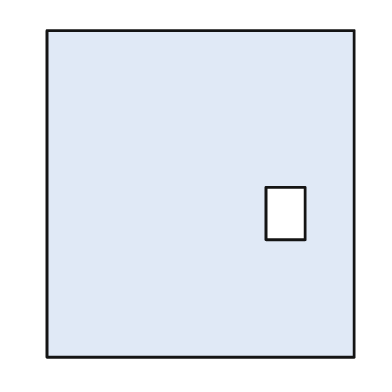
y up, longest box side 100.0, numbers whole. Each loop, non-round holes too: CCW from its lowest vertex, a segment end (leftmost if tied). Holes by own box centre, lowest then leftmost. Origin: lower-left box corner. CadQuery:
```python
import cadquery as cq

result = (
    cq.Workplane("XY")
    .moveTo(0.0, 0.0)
    .lineTo(94.0, 0.0)
    .lineTo(94.0, 100.0)
    .lineTo(0.0, 100.0)
    .close()
    .moveTo(67.0, 36.0)
    .lineTo(79.0, 36.0)
    .lineTo(79.0, 52.0)
    .lineTo(67.0, 52.0)
    .close()
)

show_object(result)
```